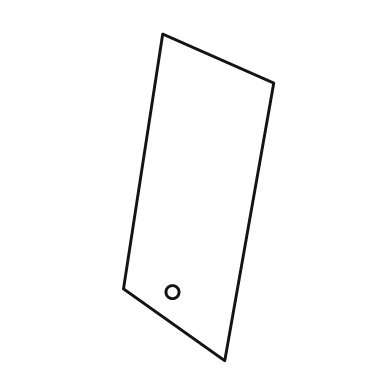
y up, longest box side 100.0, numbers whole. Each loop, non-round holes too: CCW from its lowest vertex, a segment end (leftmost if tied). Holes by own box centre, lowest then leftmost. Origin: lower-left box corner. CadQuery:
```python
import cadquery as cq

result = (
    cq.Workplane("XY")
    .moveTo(31.0, 0.0)
    .lineTo(46.0, 85.0)
    .lineTo(12.0, 100.0)
    .lineTo(0.0, 22.0)
    .close()
    .moveTo(15.0, 21.0)
    .circle(2.0)
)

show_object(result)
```